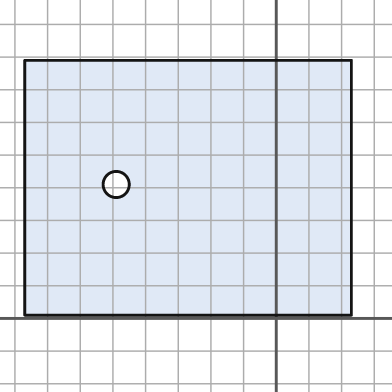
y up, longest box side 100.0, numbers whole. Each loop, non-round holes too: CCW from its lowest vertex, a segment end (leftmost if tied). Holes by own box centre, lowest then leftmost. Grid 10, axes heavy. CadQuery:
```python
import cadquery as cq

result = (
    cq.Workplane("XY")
    .moveTo(-77.0, 1.0)
    .lineTo(23.0, 1.0)
    .lineTo(23.0, 79.0)
    .lineTo(-77.0, 79.0)
    .close()
    .moveTo(-49.0, 41.0)
    .circle(4.0)
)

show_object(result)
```